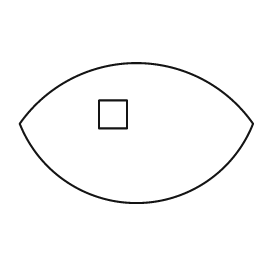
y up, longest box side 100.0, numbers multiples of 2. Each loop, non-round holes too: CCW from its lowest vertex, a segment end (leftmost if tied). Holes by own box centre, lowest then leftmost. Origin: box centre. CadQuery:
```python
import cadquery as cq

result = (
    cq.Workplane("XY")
    .moveTo(-50.0, 4.0)
    .threePointArc((0.0, -30.0), (50.0, 4.0))
    .threePointArc((0.0, 30.0), (-50.0, 4.0))
    .close()
    .moveTo(-16.0, 2.0)
    .lineTo(-4.0, 2.0)
    .lineTo(-4.0, 14.0)
    .lineTo(-16.0, 14.0)
    .close()
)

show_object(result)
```